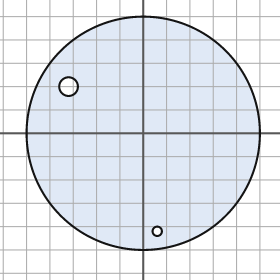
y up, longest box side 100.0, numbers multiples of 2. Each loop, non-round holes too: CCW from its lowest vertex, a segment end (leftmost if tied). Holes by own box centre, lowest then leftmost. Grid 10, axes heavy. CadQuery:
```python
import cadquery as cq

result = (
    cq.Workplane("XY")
    .moveTo(0.0, 0.0)
    .circle(50.0)
    .moveTo(6.0, -42.0)
    .circle(2.0)
    .moveTo(-32.0, 20.0)
    .circle(4.0)
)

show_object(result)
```